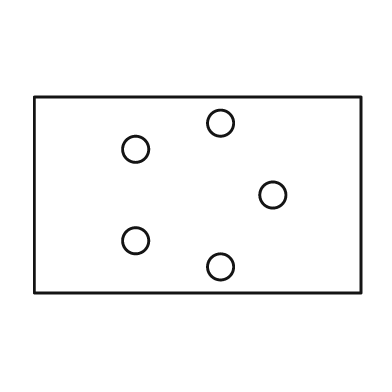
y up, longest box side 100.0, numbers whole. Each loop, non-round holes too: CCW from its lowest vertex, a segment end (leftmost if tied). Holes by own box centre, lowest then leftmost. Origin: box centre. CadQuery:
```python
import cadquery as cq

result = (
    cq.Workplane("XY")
    .moveTo(-50.0, -30.0)
    .lineTo(50.0, -30.0)
    .lineTo(50.0, 30.0)
    .lineTo(-50.0, 30.0)
    .close()
    .moveTo(7.0, -22.0)
    .circle(4.0)
    .moveTo(-19.0, -14.0)
    .circle(4.0)
    .moveTo(23.0, 0.0)
    .circle(4.0)
    .moveTo(-19.0, 14.0)
    .circle(4.0)
    .moveTo(7.0, 22.0)
    .circle(4.0)
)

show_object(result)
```